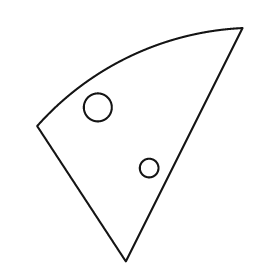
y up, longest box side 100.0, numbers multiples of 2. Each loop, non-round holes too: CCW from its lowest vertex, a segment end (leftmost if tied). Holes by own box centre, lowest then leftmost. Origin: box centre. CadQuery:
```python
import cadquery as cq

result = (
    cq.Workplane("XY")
    .moveTo(-6.0, -50.0)
    .lineTo(44.0, 50.0)
    .threePointArc((-4.0, 38.0), (-44.0, 8.0))
    .close()
    .moveTo(4.0, -10.0)
    .circle(4.0)
    .moveTo(-18.0, 16.0)
    .circle(6.0)
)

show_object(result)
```